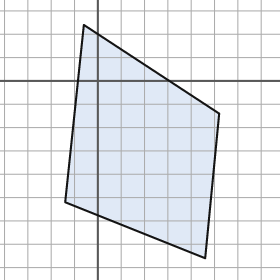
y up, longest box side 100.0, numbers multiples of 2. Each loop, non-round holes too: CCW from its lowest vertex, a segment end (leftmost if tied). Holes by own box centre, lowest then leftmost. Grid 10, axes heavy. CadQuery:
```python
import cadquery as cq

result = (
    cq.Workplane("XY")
    .moveTo(46.0, -76.0)
    .lineTo(52.0, -14.0)
    .lineTo(-6.0, 24.0)
    .lineTo(-14.0, -52.0)
    .close()
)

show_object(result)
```